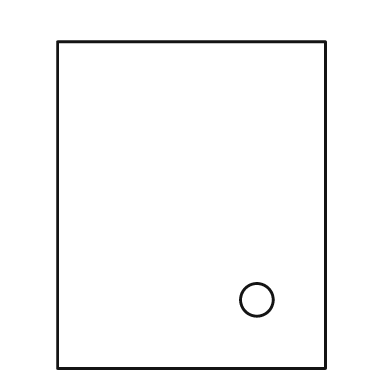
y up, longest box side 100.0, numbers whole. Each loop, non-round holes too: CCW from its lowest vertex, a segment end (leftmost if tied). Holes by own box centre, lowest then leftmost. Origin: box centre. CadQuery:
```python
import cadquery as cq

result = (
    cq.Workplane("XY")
    .moveTo(-41.0, -50.0)
    .lineTo(41.0, -50.0)
    .lineTo(41.0, 50.0)
    .lineTo(-41.0, 50.0)
    .close()
    .moveTo(20.0, -29.0)
    .circle(5.0)
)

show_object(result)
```